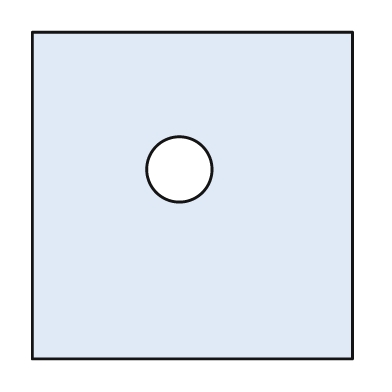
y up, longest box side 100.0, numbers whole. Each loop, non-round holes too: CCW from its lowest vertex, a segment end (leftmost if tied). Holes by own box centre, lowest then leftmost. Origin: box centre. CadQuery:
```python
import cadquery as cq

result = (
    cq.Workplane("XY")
    .moveTo(-49.0, -50.0)
    .lineTo(49.0, -50.0)
    .lineTo(49.0, 50.0)
    .lineTo(-49.0, 50.0)
    .close()
    .moveTo(-4.0, 8.0)
    .circle(10.0)
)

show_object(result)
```